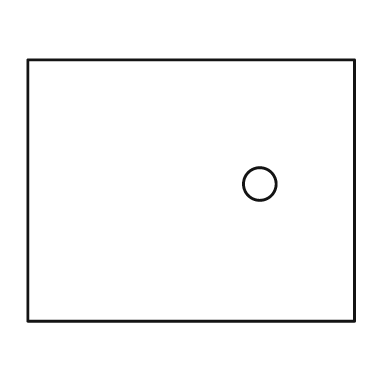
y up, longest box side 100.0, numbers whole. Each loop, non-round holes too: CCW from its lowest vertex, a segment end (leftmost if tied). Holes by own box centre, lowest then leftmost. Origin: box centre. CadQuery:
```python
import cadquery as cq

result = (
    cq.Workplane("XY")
    .moveTo(-50.0, -40.0)
    .lineTo(50.0, -40.0)
    .lineTo(50.0, 40.0)
    .lineTo(-50.0, 40.0)
    .close()
    .moveTo(21.0, 2.0)
    .circle(5.0)
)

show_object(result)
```